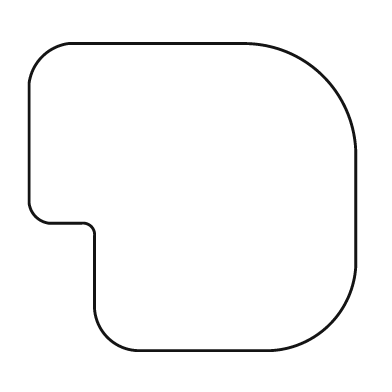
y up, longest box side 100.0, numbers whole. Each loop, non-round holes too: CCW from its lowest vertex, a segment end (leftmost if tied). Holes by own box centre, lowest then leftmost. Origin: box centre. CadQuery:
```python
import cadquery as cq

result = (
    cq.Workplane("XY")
    .moveTo(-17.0, -47.0)
    .lineTo(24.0, -47.0)
    .threePointArc((42.0, -39.0), (50.0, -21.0))
    .lineTo(50.0, 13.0)
    .threePointArc((40.0, 37.0), (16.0, 47.0))
    .lineTo(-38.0, 47.0)
    .threePointArc((-46.0, 43.0), (-50.0, 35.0))
    .lineTo(-50.0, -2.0)
    .threePointArc((-48.0, -6.0), (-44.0, -8.0))
    .lineTo(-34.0, -8.0)
    .threePointArc((-31.0, -9.0), (-30.0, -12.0))
    .lineTo(-30.0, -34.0)
    .threePointArc((-26.0, -43.0), (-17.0, -47.0))
    .close()
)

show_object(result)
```